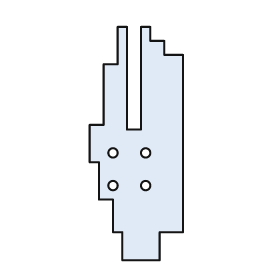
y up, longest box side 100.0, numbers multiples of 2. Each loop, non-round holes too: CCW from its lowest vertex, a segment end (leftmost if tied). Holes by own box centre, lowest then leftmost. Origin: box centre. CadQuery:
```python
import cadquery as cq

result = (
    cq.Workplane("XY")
    .moveTo(-6.0, -50.0)
    .lineTo(10.0, -50.0)
    .lineTo(10.0, -38.0)
    .lineTo(20.0, -38.0)
    .lineTo(20.0, 38.0)
    .lineTo(12.0, 38.0)
    .lineTo(12.0, 44.0)
    .lineTo(6.0, 44.0)
    .lineTo(6.0, 50.0)
    .lineTo(2.0, 50.0)
    .lineTo(2.0, 6.0)
    .lineTo(-4.0, 6.0)
    .lineTo(-4.0, 50.0)
    .lineTo(-8.0, 50.0)
    .lineTo(-8.0, 34.0)
    .lineTo(-14.0, 34.0)
    .lineTo(-14.0, 8.0)
    .lineTo(-20.0, 8.0)
    .lineTo(-20.0, -8.0)
    .lineTo(-16.0, -8.0)
    .lineTo(-16.0, -24.0)
    .lineTo(-10.0, -24.0)
    .lineTo(-10.0, -38.0)
    .lineTo(-6.0, -38.0)
    .close()
    .moveTo(-10.0, -18.0)
    .circle(2.0)
    .moveTo(4.0, -18.0)
    .circle(2.0)
    .moveTo(-10.0, -4.0)
    .circle(2.0)
    .moveTo(4.0, -4.0)
    .circle(2.0)
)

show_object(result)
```